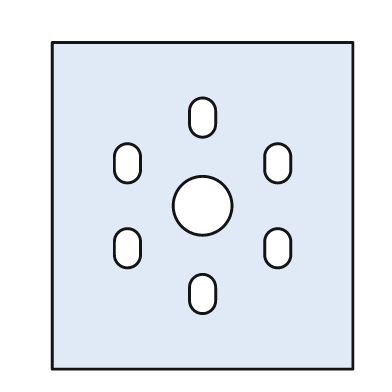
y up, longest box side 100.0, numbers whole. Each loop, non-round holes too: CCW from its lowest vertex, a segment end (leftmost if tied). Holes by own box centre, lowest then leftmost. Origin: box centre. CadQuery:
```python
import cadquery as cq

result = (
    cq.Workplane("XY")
    .moveTo(-46.0, -50.0)
    .lineTo(46.0, -50.0)
    .lineTo(46.0, 50.0)
    .lineTo(-46.0, 50.0)
    .close()
    .moveTo(-4.0, -29.0)
    .threePointArc((0.0, -33.0), (4.0, -29.0))
    .lineTo(4.0, -25.0)
    .threePointArc((0.0, -21.0), (-4.0, -25.0))
    .close()
    .moveTo(-27.0, -15.0)
    .threePointArc((-23.0, -19.0), (-19.0, -15.0))
    .lineTo(-19.0, -11.0)
    .threePointArc((-23.0, -7.0), (-27.0, -11.0))
    .close()
    .moveTo(19.0, -15.0)
    .threePointArc((23.0, -19.0), (27.0, -15.0))
    .lineTo(27.0, -11.0)
    .threePointArc((23.0, -7.0), (19.0, -11.0))
    .close()
    .moveTo(0.0, 0.0)
    .circle(9.0)
    .moveTo(-27.0, 11.0)
    .threePointArc((-23.0, 7.0), (-19.0, 11.0))
    .lineTo(-19.0, 15.0)
    .threePointArc((-23.0, 19.0), (-27.0, 15.0))
    .close()
    .moveTo(19.0, 11.0)
    .threePointArc((23.0, 7.0), (27.0, 11.0))
    .lineTo(27.0, 15.0)
    .threePointArc((23.0, 19.0), (19.0, 15.0))
    .close()
    .moveTo(-4.0, 25.0)
    .threePointArc((0.0, 21.0), (4.0, 25.0))
    .lineTo(4.0, 29.0)
    .threePointArc((0.0, 33.0), (-4.0, 29.0))
    .close()
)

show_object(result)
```